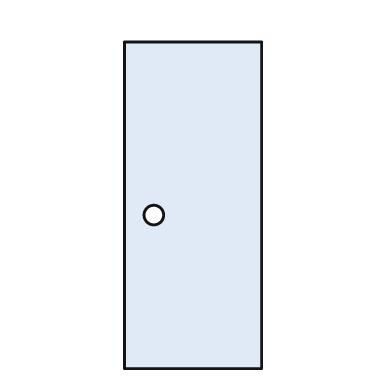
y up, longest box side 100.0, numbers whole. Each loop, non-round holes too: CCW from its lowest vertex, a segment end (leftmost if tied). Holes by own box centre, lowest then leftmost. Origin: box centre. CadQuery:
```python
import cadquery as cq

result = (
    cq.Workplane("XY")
    .moveTo(-21.0, -50.0)
    .lineTo(21.0, -50.0)
    .lineTo(21.0, 50.0)
    .lineTo(-21.0, 50.0)
    .close()
    .moveTo(-12.0, -3.0)
    .circle(3.0)
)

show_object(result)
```